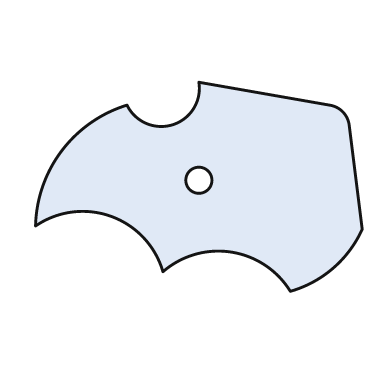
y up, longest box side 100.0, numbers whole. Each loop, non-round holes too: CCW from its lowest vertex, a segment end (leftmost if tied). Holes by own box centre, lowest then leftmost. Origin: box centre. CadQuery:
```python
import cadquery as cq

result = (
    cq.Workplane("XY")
    .moveTo(28.0, -32.0)
    .threePointArc((41.0, -25.0), (50.0, -13.0))
    .lineTo(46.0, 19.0)
    .threePointArc((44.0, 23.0), (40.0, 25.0))
    .lineTo(0.0, 32.0)
    .threePointArc((-8.0, 19.0), (-22.0, 25.0))
    .threePointArc((-42.0, 11.0), (-50.0, -12.0))
    .threePointArc((-27.0, -9.0), (-11.0, -26.0))
    .threePointArc((10.0, -20.0), (28.0, -32.0))
    .close()
    .moveTo(0.0, 2.0)
    .circle(4.0)
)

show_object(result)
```